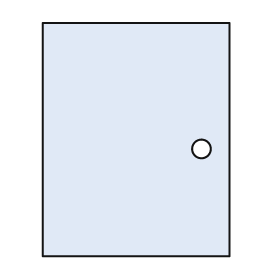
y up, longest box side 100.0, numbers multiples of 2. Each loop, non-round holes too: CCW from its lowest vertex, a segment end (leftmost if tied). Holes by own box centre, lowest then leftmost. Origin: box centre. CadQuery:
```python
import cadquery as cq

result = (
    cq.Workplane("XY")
    .moveTo(-40.0, -50.0)
    .lineTo(40.0, -50.0)
    .lineTo(40.0, 50.0)
    .lineTo(-40.0, 50.0)
    .close()
    .moveTo(28.0, -4.0)
    .circle(4.0)
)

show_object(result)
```